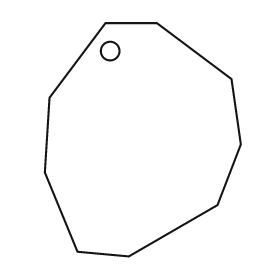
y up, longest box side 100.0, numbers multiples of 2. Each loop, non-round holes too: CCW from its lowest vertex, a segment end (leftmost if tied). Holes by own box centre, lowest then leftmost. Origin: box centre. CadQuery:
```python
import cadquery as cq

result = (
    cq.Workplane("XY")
    .moveTo(-6.0, -50.0)
    .lineTo(32.0, -28.0)
    .lineTo(42.0, -2.0)
    .lineTo(38.0, 26.0)
    .lineTo(6.0, 50.0)
    .lineTo(-16.0, 50.0)
    .lineTo(-40.0, 18.0)
    .lineTo(-42.0, -14.0)
    .lineTo(-28.0, -48.0)
    .close()
    .moveTo(-14.0, 38.0)
    .circle(4.0)
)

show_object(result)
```